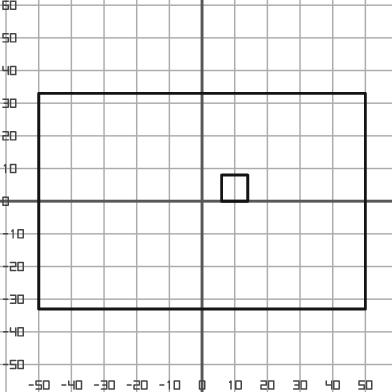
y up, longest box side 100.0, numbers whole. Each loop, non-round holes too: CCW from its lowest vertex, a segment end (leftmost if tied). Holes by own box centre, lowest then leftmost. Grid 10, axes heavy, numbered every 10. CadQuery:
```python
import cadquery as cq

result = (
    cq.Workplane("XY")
    .moveTo(-50.0, -33.0)
    .lineTo(50.0, -33.0)
    .lineTo(50.0, 33.0)
    .lineTo(-50.0, 33.0)
    .close()
    .moveTo(6.0, 0.0)
    .lineTo(14.0, 0.0)
    .lineTo(14.0, 8.0)
    .lineTo(6.0, 8.0)
    .close()
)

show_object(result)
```